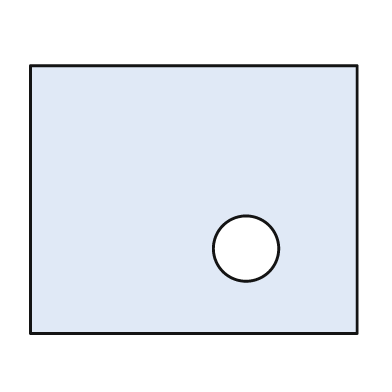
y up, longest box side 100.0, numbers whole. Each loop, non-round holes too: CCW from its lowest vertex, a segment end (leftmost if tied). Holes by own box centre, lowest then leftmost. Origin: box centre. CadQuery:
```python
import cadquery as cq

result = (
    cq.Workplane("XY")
    .moveTo(-50.0, -41.0)
    .lineTo(50.0, -41.0)
    .lineTo(50.0, 41.0)
    .lineTo(-50.0, 41.0)
    .close()
    .moveTo(16.0, -15.0)
    .circle(10.0)
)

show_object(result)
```